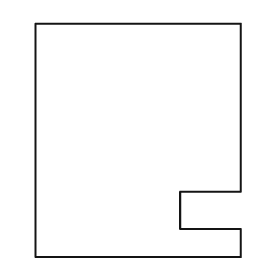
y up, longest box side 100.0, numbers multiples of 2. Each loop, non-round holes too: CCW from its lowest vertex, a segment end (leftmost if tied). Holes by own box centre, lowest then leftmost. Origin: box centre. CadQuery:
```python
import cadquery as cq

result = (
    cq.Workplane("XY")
    .moveTo(-44.0, -50.0)
    .lineTo(44.0, -50.0)
    .lineTo(44.0, -38.0)
    .lineTo(18.0, -38.0)
    .lineTo(18.0, -22.0)
    .lineTo(44.0, -22.0)
    .lineTo(44.0, 50.0)
    .lineTo(-44.0, 50.0)
    .close()
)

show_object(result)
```